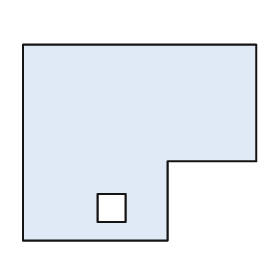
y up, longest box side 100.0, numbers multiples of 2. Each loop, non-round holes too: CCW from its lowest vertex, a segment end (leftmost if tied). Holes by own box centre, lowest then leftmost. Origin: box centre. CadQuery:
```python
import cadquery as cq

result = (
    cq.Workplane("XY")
    .moveTo(-50.0, -42.0)
    .lineTo(12.0, -42.0)
    .lineTo(12.0, -8.0)
    .lineTo(50.0, -8.0)
    .lineTo(50.0, 42.0)
    .lineTo(-50.0, 42.0)
    .close()
    .moveTo(-18.0, -34.0)
    .lineTo(-6.0, -34.0)
    .lineTo(-6.0, -22.0)
    .lineTo(-18.0, -22.0)
    .close()
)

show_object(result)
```